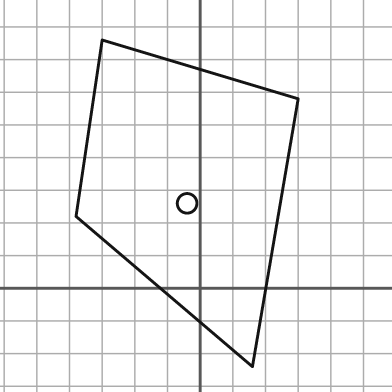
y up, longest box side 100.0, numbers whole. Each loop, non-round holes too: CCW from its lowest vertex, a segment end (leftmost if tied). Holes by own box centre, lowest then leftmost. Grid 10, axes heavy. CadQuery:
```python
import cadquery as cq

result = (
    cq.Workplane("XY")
    .moveTo(16.0, -24.0)
    .lineTo(30.0, 58.0)
    .lineTo(-30.0, 76.0)
    .lineTo(-38.0, 22.0)
    .close()
    .moveTo(-4.0, 26.0)
    .circle(3.0)
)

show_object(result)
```